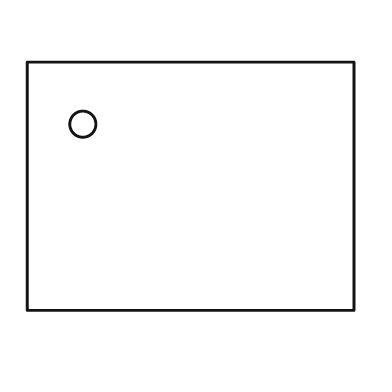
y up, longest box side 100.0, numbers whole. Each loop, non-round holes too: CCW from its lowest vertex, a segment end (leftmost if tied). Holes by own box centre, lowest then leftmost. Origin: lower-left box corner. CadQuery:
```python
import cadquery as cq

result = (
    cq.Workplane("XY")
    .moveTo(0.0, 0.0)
    .lineTo(100.0, 0.0)
    .lineTo(100.0, 76.0)
    .lineTo(0.0, 76.0)
    .close()
    .moveTo(17.0, 57.0)
    .circle(4.0)
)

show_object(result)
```